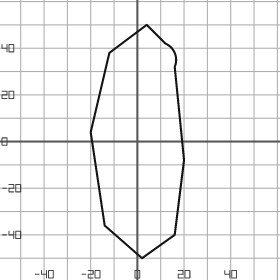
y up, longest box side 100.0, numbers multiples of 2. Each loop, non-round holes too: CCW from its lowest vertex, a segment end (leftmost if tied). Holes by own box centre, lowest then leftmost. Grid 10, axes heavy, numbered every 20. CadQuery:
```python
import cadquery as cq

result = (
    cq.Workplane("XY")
    .moveTo(2.0, -50.0)
    .lineTo(16.0, -40.0)
    .lineTo(20.0, -8.0)
    .lineTo(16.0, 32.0)
    .threePointArc((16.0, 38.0), (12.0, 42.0))
    .lineTo(4.0, 50.0)
    .lineTo(-12.0, 38.0)
    .lineTo(-20.0, 4.0)
    .lineTo(-14.0, -36.0)
    .close()
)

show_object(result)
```